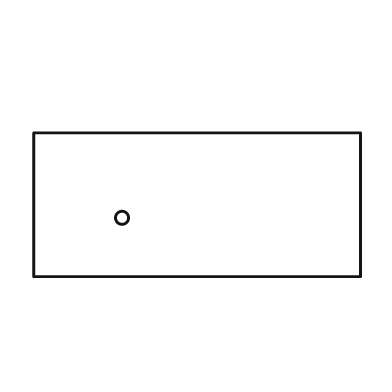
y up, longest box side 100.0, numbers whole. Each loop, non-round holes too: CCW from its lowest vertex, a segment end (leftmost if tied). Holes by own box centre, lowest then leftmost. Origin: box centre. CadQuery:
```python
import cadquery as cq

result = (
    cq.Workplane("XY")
    .moveTo(-50.0, -22.0)
    .lineTo(50.0, -22.0)
    .lineTo(50.0, 22.0)
    .lineTo(-50.0, 22.0)
    .close()
    .moveTo(-23.0, -4.0)
    .circle(2.0)
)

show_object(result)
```